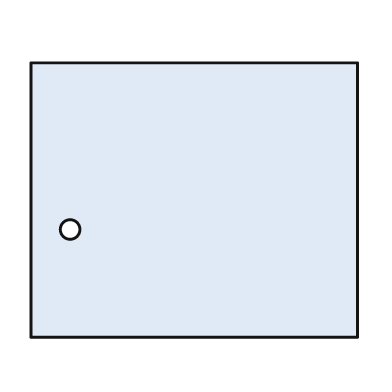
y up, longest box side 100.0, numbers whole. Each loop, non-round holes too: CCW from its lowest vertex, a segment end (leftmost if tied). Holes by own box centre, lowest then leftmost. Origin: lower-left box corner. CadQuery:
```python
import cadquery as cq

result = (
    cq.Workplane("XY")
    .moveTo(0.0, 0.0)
    .lineTo(100.0, 0.0)
    .lineTo(100.0, 84.0)
    .lineTo(0.0, 84.0)
    .close()
    .moveTo(12.0, 33.0)
    .circle(3.0)
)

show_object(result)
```